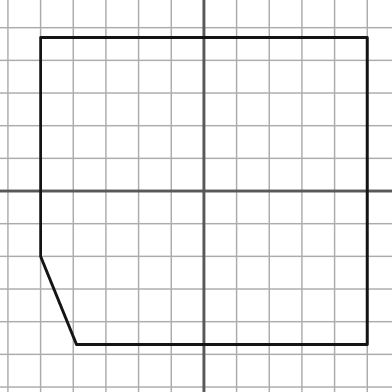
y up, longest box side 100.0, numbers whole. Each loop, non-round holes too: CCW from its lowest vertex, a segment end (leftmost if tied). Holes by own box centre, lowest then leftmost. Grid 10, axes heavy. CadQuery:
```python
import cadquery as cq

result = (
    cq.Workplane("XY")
    .moveTo(-39.0, -47.0)
    .lineTo(50.0, -47.0)
    .lineTo(50.0, 47.0)
    .lineTo(-50.0, 47.0)
    .lineTo(-50.0, -20.0)
    .close()
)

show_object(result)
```